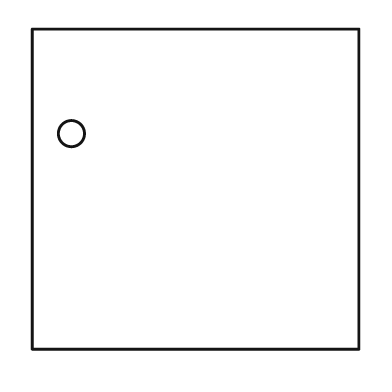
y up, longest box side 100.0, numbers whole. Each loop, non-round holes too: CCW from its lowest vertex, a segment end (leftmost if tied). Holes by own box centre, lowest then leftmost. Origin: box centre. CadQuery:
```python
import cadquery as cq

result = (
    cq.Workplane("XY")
    .moveTo(-50.0, -49.0)
    .lineTo(50.0, -49.0)
    .lineTo(50.0, 49.0)
    .lineTo(-50.0, 49.0)
    .close()
    .moveTo(-38.0, 17.0)
    .circle(4.0)
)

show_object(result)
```